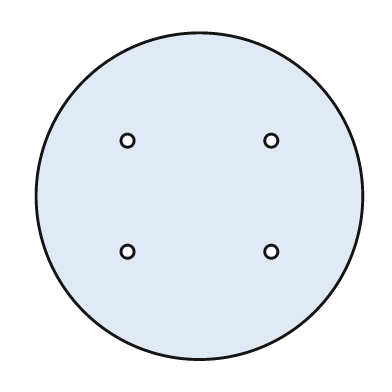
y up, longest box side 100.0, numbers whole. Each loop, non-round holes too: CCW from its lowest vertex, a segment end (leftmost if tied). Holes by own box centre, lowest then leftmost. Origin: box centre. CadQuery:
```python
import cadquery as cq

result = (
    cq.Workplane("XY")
    .moveTo(0.0, 0.0)
    .circle(50.0)
    .moveTo(-22.0, -17.0)
    .circle(2.0)
    .moveTo(22.0, -17.0)
    .circle(2.0)
    .moveTo(-22.0, 17.0)
    .circle(2.0)
    .moveTo(22.0, 17.0)
    .circle(2.0)
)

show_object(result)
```